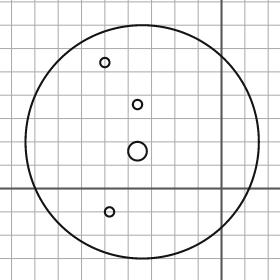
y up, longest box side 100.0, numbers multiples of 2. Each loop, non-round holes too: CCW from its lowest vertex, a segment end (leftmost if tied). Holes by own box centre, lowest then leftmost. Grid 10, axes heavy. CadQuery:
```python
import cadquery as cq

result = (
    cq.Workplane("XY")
    .moveTo(-34.0, 20.0)
    .circle(50.0)
    .moveTo(-48.0, -10.0)
    .circle(2.0)
    .moveTo(-36.0, 16.0)
    .circle(4.0)
    .moveTo(-36.0, 36.0)
    .circle(2.0)
    .moveTo(-50.0, 54.0)
    .circle(2.0)
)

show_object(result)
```